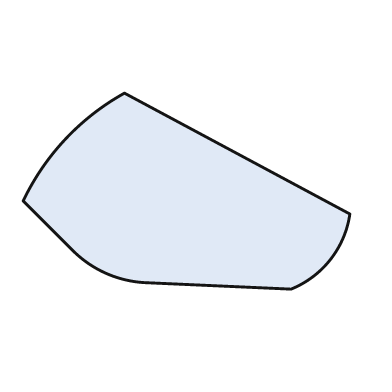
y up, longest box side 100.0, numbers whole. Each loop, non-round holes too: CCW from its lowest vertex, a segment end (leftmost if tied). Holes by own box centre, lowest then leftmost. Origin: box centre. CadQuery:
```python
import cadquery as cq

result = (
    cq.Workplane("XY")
    .moveTo(32.0, -30.0)
    .threePointArc((44.0, -21.0), (50.0, -7.0))
    .lineTo(-19.0, 30.0)
    .threePointArc((-37.0, 16.0), (-50.0, -3.0))
    .lineTo(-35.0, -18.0)
    .threePointArc((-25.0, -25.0), (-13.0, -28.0))
    .close()
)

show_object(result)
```